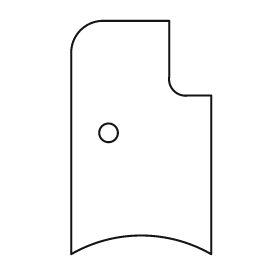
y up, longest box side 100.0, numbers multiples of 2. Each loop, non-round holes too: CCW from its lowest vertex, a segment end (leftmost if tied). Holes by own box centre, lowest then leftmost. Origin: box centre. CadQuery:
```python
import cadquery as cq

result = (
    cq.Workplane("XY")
    .moveTo(-30.0, -50.0)
    .threePointArc((0.0, -42.0), (30.0, -50.0))
    .lineTo(30.0, 18.0)
    .lineTo(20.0, 18.0)
    .threePointArc((14.0, 20.0), (12.0, 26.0))
    .lineTo(12.0, 50.0)
    .lineTo(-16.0, 50.0)
    .threePointArc((-26.0, 46.0), (-30.0, 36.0))
    .close()
    .moveTo(-14.0, 2.0)
    .circle(4.0)
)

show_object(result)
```